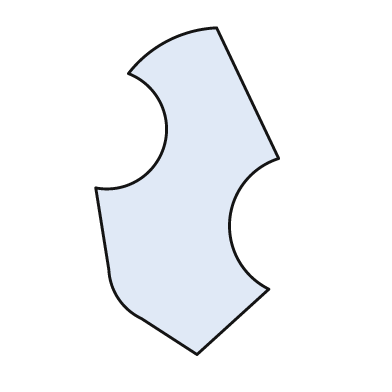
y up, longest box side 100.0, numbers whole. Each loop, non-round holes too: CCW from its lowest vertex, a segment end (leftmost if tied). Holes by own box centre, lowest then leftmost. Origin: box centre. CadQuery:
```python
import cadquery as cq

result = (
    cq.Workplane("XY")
    .moveTo(3.0, -50.0)
    .lineTo(25.0, -30.0)
    .threePointArc((13.0, -9.0), (28.0, 10.0))
    .lineTo(9.0, 50.0)
    .threePointArc((-6.0, 46.0), (-18.0, 36.0))
    .threePointArc((-7.0, 14.0), (-28.0, 1.0))
    .lineTo(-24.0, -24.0)
    .threePointArc((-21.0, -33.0), (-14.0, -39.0))
    .close()
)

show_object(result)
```